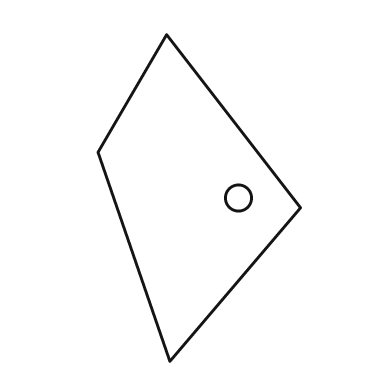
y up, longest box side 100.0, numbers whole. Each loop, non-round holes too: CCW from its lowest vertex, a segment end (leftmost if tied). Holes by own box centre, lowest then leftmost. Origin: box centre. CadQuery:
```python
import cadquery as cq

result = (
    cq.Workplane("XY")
    .moveTo(-9.0, -50.0)
    .lineTo(31.0, -3.0)
    .lineTo(-10.0, 50.0)
    .lineTo(-31.0, 14.0)
    .close()
    .moveTo(12.0, 0.0)
    .circle(4.0)
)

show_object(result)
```